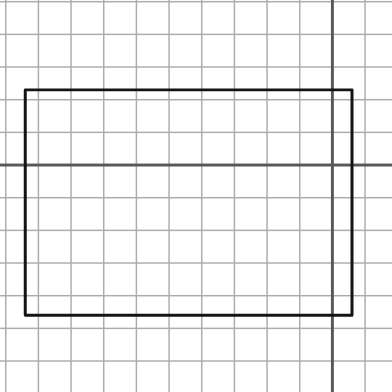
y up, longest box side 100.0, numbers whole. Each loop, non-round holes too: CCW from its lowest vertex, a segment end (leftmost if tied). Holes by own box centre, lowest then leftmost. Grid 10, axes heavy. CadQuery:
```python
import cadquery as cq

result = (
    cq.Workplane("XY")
    .moveTo(-94.0, -46.0)
    .lineTo(6.0, -46.0)
    .lineTo(6.0, 23.0)
    .lineTo(-94.0, 23.0)
    .close()
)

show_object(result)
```